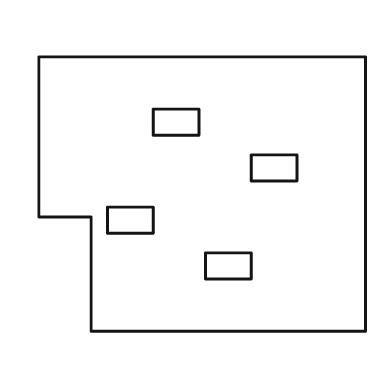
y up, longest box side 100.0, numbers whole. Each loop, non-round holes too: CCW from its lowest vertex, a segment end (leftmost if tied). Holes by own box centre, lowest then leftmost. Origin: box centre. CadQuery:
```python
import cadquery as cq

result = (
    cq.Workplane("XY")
    .moveTo(-34.0, -42.0)
    .lineTo(50.0, -42.0)
    .lineTo(50.0, 42.0)
    .lineTo(-50.0, 42.0)
    .lineTo(-50.0, -7.0)
    .lineTo(-34.0, -7.0)
    .close()
    .moveTo(1.0, -26.0)
    .lineTo(15.0, -26.0)
    .lineTo(15.0, -18.0)
    .lineTo(1.0, -18.0)
    .close()
    .moveTo(-29.0, -12.0)
    .lineTo(-15.0, -12.0)
    .lineTo(-15.0, -4.0)
    .lineTo(-29.0, -4.0)
    .close()
    .moveTo(15.0, 4.0)
    .lineTo(29.0, 4.0)
    .lineTo(29.0, 12.0)
    .lineTo(15.0, 12.0)
    .close()
    .moveTo(-15.0, 18.0)
    .lineTo(-1.0, 18.0)
    .lineTo(-1.0, 26.0)
    .lineTo(-15.0, 26.0)
    .close()
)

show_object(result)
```